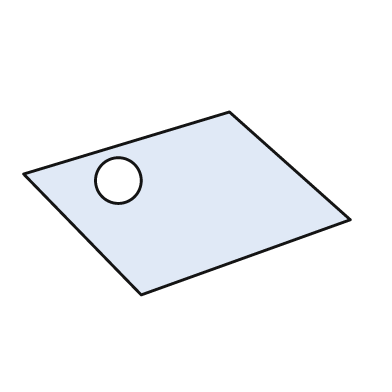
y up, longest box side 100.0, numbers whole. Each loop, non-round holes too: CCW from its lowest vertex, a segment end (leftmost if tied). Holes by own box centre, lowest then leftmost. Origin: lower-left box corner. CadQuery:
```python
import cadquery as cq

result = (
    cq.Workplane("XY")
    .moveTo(36.0, 0.0)
    .lineTo(100.0, 23.0)
    .lineTo(63.0, 56.0)
    .lineTo(0.0, 37.0)
    .close()
    .moveTo(29.0, 35.0)
    .circle(7.0)
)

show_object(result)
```